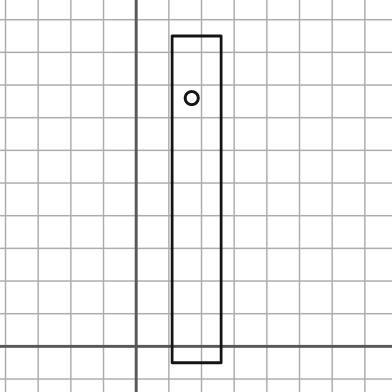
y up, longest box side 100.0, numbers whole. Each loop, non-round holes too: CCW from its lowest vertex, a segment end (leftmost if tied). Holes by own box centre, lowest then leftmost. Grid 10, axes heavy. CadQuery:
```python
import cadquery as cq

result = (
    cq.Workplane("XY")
    .moveTo(11.0, -5.0)
    .lineTo(26.0, -5.0)
    .lineTo(26.0, 95.0)
    .lineTo(11.0, 95.0)
    .close()
    .moveTo(17.0, 76.0)
    .circle(2.0)
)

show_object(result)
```